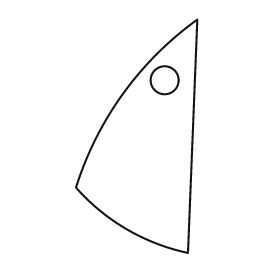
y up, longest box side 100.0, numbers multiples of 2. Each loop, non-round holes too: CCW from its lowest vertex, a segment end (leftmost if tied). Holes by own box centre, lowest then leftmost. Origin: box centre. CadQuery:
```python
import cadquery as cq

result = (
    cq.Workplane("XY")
    .moveTo(22.0, -50.0)
    .lineTo(26.0, 50.0)
    .threePointArc((-6.0, 18.0), (-26.0, -22.0))
    .threePointArc((-4.0, -40.0), (22.0, -50.0))
    .close()
    .moveTo(12.0, 24.0)
    .circle(6.0)
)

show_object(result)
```